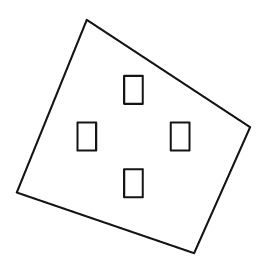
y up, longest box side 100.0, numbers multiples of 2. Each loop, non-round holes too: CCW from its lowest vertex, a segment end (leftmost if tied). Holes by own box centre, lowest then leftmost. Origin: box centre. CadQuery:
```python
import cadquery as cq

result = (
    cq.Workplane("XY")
    .moveTo(26.0, -50.0)
    .lineTo(50.0, 4.0)
    .lineTo(-20.0, 50.0)
    .lineTo(-50.0, -24.0)
    .close()
    .moveTo(-4.0, -26.0)
    .lineTo(4.0, -26.0)
    .lineTo(4.0, -14.0)
    .lineTo(-4.0, -14.0)
    .close()
    .moveTo(-24.0, -6.0)
    .lineTo(-16.0, -6.0)
    .lineTo(-16.0, 6.0)
    .lineTo(-24.0, 6.0)
    .close()
    .moveTo(16.0, -6.0)
    .lineTo(24.0, -6.0)
    .lineTo(24.0, 6.0)
    .lineTo(16.0, 6.0)
    .close()
    .moveTo(-4.0, 14.0)
    .lineTo(4.0, 14.0)
    .lineTo(4.0, 26.0)
    .lineTo(-4.0, 26.0)
    .close()
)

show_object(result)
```